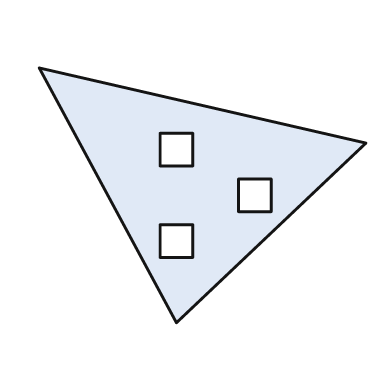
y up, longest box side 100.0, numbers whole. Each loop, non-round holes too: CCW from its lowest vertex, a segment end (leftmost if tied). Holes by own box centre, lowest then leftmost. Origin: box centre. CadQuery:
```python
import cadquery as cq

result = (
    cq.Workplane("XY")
    .moveTo(-8.0, -39.0)
    .lineTo(50.0, 16.0)
    .lineTo(-50.0, 39.0)
    .close()
    .moveTo(-13.0, -19.0)
    .lineTo(-3.0, -19.0)
    .lineTo(-3.0, -9.0)
    .lineTo(-13.0, -9.0)
    .close()
    .moveTo(11.0, -5.0)
    .lineTo(21.0, -5.0)
    .lineTo(21.0, 5.0)
    .lineTo(11.0, 5.0)
    .close()
    .moveTo(-13.0, 9.0)
    .lineTo(-3.0, 9.0)
    .lineTo(-3.0, 19.0)
    .lineTo(-13.0, 19.0)
    .close()
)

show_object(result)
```